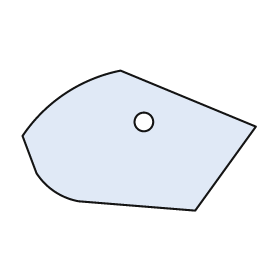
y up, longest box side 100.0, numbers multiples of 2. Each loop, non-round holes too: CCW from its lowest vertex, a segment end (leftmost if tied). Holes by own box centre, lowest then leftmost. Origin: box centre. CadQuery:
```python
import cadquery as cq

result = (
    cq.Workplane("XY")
    .moveTo(24.0, -30.0)
    .lineTo(50.0, 6.0)
    .lineTo(-8.0, 30.0)
    .threePointArc((-32.0, 20.0), (-50.0, 2.0))
    .lineTo(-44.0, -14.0)
    .threePointArc((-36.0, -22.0), (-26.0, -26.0))
    .close()
    .moveTo(2.0, 8.0)
    .circle(4.0)
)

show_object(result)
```